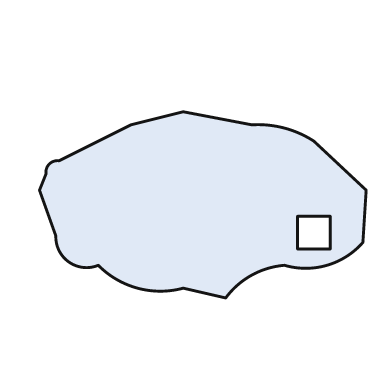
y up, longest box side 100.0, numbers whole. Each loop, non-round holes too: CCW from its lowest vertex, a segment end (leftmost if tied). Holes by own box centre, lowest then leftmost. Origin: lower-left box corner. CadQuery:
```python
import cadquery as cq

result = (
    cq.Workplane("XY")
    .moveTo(57.0, 0.0)
    .threePointArc((65.0, 7.0), (75.0, 10.0))
    .threePointArc((88.0, 10.0), (99.0, 17.0))
    .lineTo(100.0, 33.0)
    .lineTo(84.0, 48.0)
    .threePointArc((75.0, 52.0), (65.0, 53.0))
    .lineTo(44.0, 57.0)
    .lineTo(28.0, 53.0)
    .lineTo(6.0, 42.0)
    .threePointArc((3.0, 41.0), (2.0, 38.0))
    .lineTo(0.0, 33.0)
    .lineTo(5.0, 19.0)
    .threePointArc((9.0, 11.0), (18.0, 10.0))
    .threePointArc((30.0, 3.0), (44.0, 3.0))
    .close()
    .moveTo(79.0, 15.0)
    .lineTo(89.0, 15.0)
    .lineTo(89.0, 25.0)
    .lineTo(79.0, 25.0)
    .close()
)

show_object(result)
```